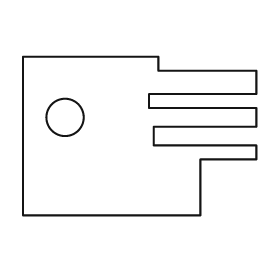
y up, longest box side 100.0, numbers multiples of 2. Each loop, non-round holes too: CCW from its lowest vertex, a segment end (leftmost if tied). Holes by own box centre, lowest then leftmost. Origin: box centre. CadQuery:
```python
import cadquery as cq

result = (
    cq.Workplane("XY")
    .moveTo(-50.0, -34.0)
    .lineTo(26.0, -34.0)
    .lineTo(26.0, -10.0)
    .lineTo(50.0, -10.0)
    .lineTo(50.0, -4.0)
    .lineTo(6.0, -4.0)
    .lineTo(6.0, 4.0)
    .lineTo(50.0, 4.0)
    .lineTo(50.0, 12.0)
    .lineTo(4.0, 12.0)
    .lineTo(4.0, 18.0)
    .lineTo(50.0, 18.0)
    .lineTo(50.0, 28.0)
    .lineTo(8.0, 28.0)
    .lineTo(8.0, 34.0)
    .lineTo(-50.0, 34.0)
    .close()
    .moveTo(-32.0, 8.0)
    .circle(8.0)
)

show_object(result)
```